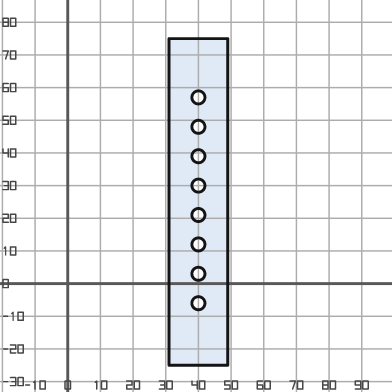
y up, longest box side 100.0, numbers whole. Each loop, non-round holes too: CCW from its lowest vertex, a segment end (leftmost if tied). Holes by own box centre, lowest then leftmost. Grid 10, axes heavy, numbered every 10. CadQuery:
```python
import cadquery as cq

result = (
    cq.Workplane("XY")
    .moveTo(31.0, -25.0)
    .lineTo(49.0, -25.0)
    .lineTo(49.0, 75.0)
    .lineTo(31.0, 75.0)
    .close()
    .moveTo(40.0, -6.0)
    .circle(2.0)
    .moveTo(40.0, 3.0)
    .circle(2.0)
    .moveTo(40.0, 12.0)
    .circle(2.0)
    .moveTo(40.0, 21.0)
    .circle(2.0)
    .moveTo(40.0, 30.0)
    .circle(2.0)
    .moveTo(40.0, 39.0)
    .circle(2.0)
    .moveTo(40.0, 48.0)
    .circle(2.0)
    .moveTo(40.0, 57.0)
    .circle(2.0)
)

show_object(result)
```